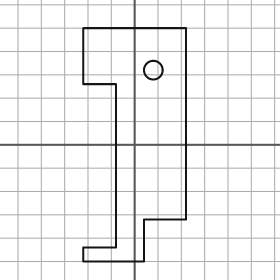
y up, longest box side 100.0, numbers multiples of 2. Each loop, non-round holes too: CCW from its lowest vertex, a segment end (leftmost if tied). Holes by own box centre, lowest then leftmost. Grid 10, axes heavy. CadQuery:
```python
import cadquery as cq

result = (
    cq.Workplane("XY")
    .moveTo(-22.0, -50.0)
    .lineTo(4.0, -50.0)
    .lineTo(4.0, -32.0)
    .lineTo(22.0, -32.0)
    .lineTo(22.0, 50.0)
    .lineTo(-22.0, 50.0)
    .lineTo(-22.0, 26.0)
    .lineTo(-8.0, 26.0)
    .lineTo(-8.0, -44.0)
    .lineTo(-22.0, -44.0)
    .close()
    .moveTo(8.0, 32.0)
    .circle(4.0)
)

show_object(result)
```